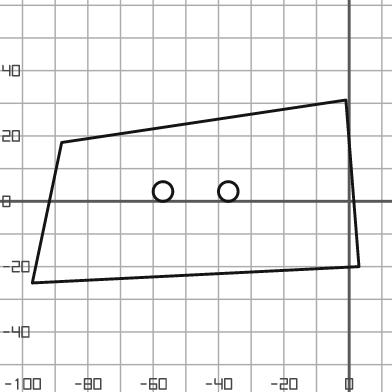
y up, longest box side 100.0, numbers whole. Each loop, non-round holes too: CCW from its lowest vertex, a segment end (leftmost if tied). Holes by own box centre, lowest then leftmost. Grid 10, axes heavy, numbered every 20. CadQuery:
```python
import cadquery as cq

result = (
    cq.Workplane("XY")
    .moveTo(-97.0, -25.0)
    .lineTo(3.0, -20.0)
    .lineTo(-1.0, 31.0)
    .lineTo(-88.0, 18.0)
    .close()
    .moveTo(-57.0, 3.0)
    .circle(3.0)
    .moveTo(-37.0, 3.0)
    .circle(3.0)
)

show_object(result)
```